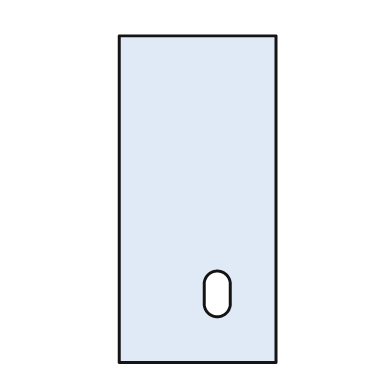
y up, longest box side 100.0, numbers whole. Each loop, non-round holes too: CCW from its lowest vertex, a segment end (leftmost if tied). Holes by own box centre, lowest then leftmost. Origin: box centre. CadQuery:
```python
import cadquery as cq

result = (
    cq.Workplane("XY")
    .moveTo(-24.0, -50.0)
    .lineTo(24.0, -50.0)
    .lineTo(24.0, 50.0)
    .lineTo(-24.0, 50.0)
    .close()
    .moveTo(2.0, -32.0)
    .threePointArc((6.0, -36.0), (10.0, -32.0))
    .lineTo(10.0, -26.0)
    .threePointArc((6.0, -22.0), (2.0, -26.0))
    .close()
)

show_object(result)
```